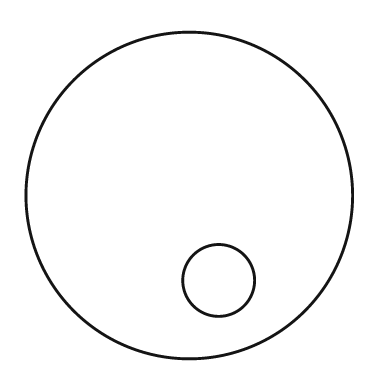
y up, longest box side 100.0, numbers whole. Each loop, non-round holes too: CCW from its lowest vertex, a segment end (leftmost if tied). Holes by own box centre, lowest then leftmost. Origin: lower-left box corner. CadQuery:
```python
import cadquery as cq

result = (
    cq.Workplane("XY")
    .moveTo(50.0, 50.0)
    .circle(50.0)
    .moveTo(59.0, 24.0)
    .circle(11.0)
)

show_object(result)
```